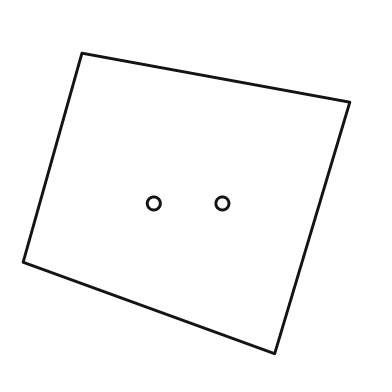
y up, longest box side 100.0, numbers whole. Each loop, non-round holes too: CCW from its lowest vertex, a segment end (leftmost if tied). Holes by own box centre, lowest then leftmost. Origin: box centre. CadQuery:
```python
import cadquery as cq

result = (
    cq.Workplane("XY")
    .moveTo(27.0, -46.0)
    .lineTo(50.0, 31.0)
    .lineTo(-32.0, 46.0)
    .lineTo(-50.0, -18.0)
    .close()
    .moveTo(-10.0, 0.0)
    .circle(2.0)
    .moveTo(11.0, 0.0)
    .circle(2.0)
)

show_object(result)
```